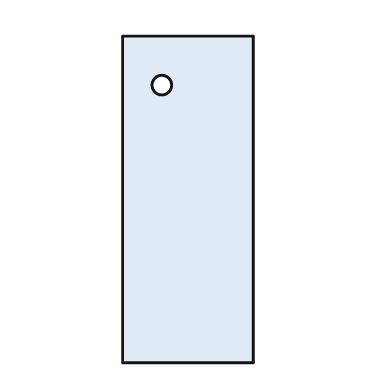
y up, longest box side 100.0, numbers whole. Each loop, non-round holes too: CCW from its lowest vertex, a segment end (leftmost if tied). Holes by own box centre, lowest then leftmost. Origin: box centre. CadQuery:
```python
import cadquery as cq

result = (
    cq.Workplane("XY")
    .moveTo(-20.0, -50.0)
    .lineTo(20.0, -50.0)
    .lineTo(20.0, 50.0)
    .lineTo(-20.0, 50.0)
    .close()
    .moveTo(-8.0, 35.0)
    .circle(3.0)
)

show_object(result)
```